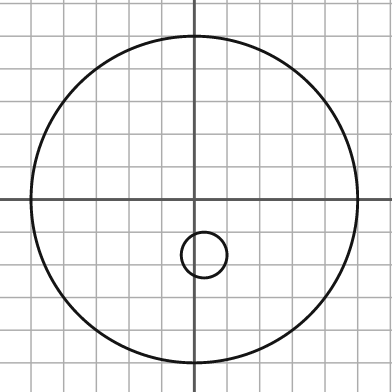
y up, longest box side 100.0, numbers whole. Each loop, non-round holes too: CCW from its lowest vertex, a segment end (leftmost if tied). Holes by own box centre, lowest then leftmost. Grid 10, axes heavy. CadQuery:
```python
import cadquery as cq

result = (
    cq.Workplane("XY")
    .moveTo(0.0, 0.0)
    .circle(50.0)
    .moveTo(3.0, -17.0)
    .circle(7.0)
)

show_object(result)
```